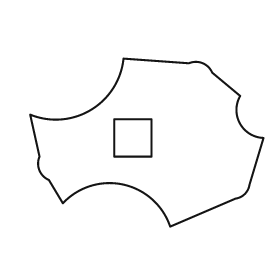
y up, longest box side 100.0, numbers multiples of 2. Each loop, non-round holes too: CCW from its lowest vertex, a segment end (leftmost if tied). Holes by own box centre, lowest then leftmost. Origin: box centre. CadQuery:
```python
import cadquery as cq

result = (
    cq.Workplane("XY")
    .moveTo(10.0, -36.0)
    .lineTo(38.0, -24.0)
    .threePointArc((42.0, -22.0), (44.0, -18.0))
    .lineTo(50.0, 2.0)
    .threePointArc((40.0, 8.0), (40.0, 20.0))
    .lineTo(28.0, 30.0)
    .threePointArc((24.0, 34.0), (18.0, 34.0))
    .lineTo(-10.0, 36.0)
    .threePointArc((-24.0, 14.0), (-50.0, 12.0))
    .lineTo(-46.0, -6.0)
    .threePointArc((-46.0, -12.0), (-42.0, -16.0))
    .lineTo(-36.0, -26.0)
    .threePointArc((-10.0, -18.0), (10.0, -36.0))
    .close()
    .moveTo(-14.0, -6.0)
    .lineTo(2.0, -6.0)
    .lineTo(2.0, 10.0)
    .lineTo(-14.0, 10.0)
    .close()
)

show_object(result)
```